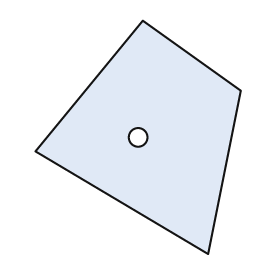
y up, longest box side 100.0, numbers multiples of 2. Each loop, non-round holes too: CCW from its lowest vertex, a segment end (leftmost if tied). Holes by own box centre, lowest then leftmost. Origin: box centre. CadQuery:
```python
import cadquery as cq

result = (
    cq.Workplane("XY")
    .moveTo(30.0, -50.0)
    .lineTo(44.0, 20.0)
    .lineTo(2.0, 50.0)
    .lineTo(-44.0, -6.0)
    .close()
    .moveTo(0.0, 0.0)
    .circle(4.0)
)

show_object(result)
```